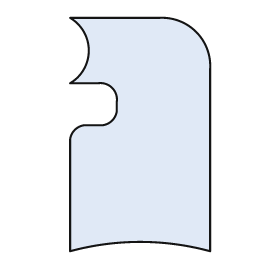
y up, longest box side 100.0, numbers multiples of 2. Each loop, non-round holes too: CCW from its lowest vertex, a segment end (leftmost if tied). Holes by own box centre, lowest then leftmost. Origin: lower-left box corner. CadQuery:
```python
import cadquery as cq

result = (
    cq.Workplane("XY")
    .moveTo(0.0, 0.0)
    .threePointArc((30.0, 4.0), (60.0, 0.0))
    .lineTo(60.0, 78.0)
    .threePointArc((54.0, 94.0), (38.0, 100.0))
    .lineTo(0.0, 100.0)
    .threePointArc((8.0, 86.0), (0.0, 72.0))
    .lineTo(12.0, 72.0)
    .threePointArc((18.0, 70.0), (20.0, 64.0))
    .lineTo(20.0, 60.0)
    .threePointArc((18.0, 56.0), (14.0, 54.0))
    .lineTo(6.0, 54.0)
    .threePointArc((2.0, 52.0), (0.0, 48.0))
    .close()
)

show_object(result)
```